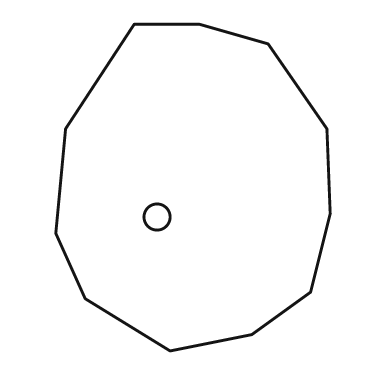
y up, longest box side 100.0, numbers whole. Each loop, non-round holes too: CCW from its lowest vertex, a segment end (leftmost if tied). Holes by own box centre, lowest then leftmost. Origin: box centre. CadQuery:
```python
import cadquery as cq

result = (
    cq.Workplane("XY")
    .moveTo(-7.0, -50.0)
    .lineTo(18.0, -45.0)
    .lineTo(36.0, -32.0)
    .lineTo(42.0, -8.0)
    .lineTo(41.0, 18.0)
    .lineTo(23.0, 44.0)
    .lineTo(2.0, 50.0)
    .lineTo(-18.0, 50.0)
    .lineTo(-39.0, 18.0)
    .lineTo(-42.0, -14.0)
    .lineTo(-33.0, -34.0)
    .close()
    .moveTo(-11.0, -9.0)
    .circle(4.0)
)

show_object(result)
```